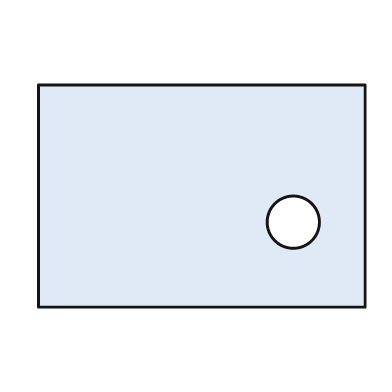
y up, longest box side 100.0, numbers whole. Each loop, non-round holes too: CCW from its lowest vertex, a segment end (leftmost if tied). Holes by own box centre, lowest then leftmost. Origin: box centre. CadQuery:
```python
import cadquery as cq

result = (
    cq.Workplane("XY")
    .moveTo(-50.0, -34.0)
    .lineTo(50.0, -34.0)
    .lineTo(50.0, 34.0)
    .lineTo(-50.0, 34.0)
    .close()
    .moveTo(28.0, -8.0)
    .circle(8.0)
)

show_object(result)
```